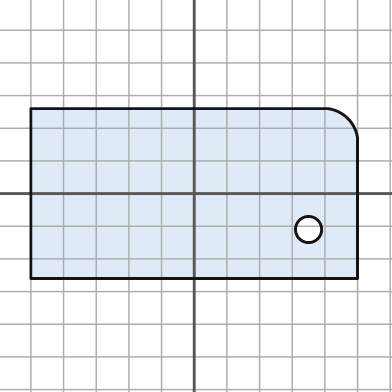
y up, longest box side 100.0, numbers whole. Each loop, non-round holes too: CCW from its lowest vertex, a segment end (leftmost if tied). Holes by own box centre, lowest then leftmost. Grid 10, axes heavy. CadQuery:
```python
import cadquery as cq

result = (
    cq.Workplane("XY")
    .moveTo(-50.0, -26.0)
    .lineTo(50.0, -26.0)
    .lineTo(50.0, 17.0)
    .threePointArc((47.0, 23.0), (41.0, 26.0))
    .lineTo(-50.0, 26.0)
    .close()
    .moveTo(35.0, -11.0)
    .circle(4.0)
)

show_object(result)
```